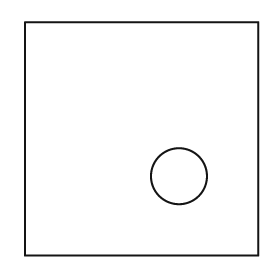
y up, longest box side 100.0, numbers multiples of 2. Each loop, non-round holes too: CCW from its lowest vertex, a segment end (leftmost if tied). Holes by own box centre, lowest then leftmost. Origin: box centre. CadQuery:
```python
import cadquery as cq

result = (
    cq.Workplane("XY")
    .moveTo(-50.0, -50.0)
    .lineTo(50.0, -50.0)
    .lineTo(50.0, 50.0)
    .lineTo(-50.0, 50.0)
    .close()
    .moveTo(16.0, -16.0)
    .circle(12.0)
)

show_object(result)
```